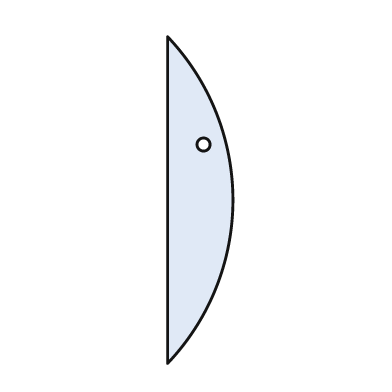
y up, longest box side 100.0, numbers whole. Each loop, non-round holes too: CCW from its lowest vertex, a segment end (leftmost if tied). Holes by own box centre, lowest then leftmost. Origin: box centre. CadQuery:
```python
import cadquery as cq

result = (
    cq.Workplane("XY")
    .moveTo(-10.0, -50.0)
    .threePointArc((10.0, 0.0), (-10.0, 50.0))
    .close()
    .moveTo(1.0, 17.0)
    .circle(2.0)
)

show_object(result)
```